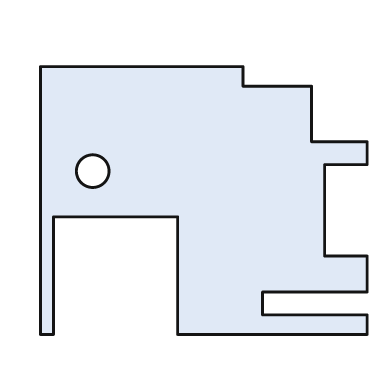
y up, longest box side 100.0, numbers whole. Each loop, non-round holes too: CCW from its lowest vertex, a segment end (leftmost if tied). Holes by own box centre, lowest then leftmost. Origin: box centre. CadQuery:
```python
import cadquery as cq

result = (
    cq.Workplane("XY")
    .moveTo(-50.0, -41.0)
    .lineTo(-46.0, -41.0)
    .lineTo(-46.0, -5.0)
    .lineTo(-8.0, -5.0)
    .lineTo(-8.0, -41.0)
    .lineTo(50.0, -41.0)
    .lineTo(50.0, -35.0)
    .lineTo(18.0, -35.0)
    .lineTo(18.0, -28.0)
    .lineTo(50.0, -28.0)
    .lineTo(50.0, -17.0)
    .lineTo(37.0, -17.0)
    .lineTo(37.0, 11.0)
    .lineTo(50.0, 11.0)
    .lineTo(50.0, 18.0)
    .lineTo(33.0, 18.0)
    .lineTo(33.0, 35.0)
    .lineTo(12.0, 35.0)
    .lineTo(12.0, 41.0)
    .lineTo(-50.0, 41.0)
    .close()
    .moveTo(-34.0, 9.0)
    .circle(5.0)
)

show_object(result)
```